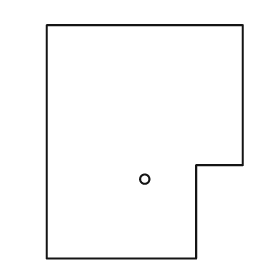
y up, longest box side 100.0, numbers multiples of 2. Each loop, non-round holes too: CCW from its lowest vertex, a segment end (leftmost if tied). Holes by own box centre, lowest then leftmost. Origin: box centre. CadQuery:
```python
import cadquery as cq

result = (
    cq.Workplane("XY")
    .moveTo(-42.0, -50.0)
    .lineTo(22.0, -50.0)
    .lineTo(22.0, -10.0)
    .lineTo(42.0, -10.0)
    .lineTo(42.0, 50.0)
    .lineTo(-42.0, 50.0)
    .close()
    .moveTo(0.0, -16.0)
    .circle(2.0)
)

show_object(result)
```